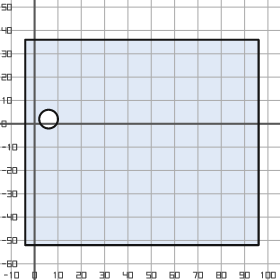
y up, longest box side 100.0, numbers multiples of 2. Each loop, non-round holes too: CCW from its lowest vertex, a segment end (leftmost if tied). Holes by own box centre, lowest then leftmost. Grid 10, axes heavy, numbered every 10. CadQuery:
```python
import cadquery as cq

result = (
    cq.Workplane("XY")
    .moveTo(-4.0, -52.0)
    .lineTo(96.0, -52.0)
    .lineTo(96.0, 36.0)
    .lineTo(-4.0, 36.0)
    .close()
    .moveTo(6.0, 2.0)
    .circle(4.0)
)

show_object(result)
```